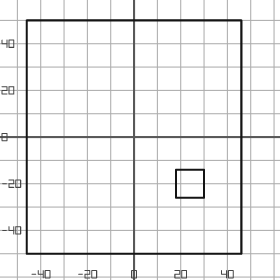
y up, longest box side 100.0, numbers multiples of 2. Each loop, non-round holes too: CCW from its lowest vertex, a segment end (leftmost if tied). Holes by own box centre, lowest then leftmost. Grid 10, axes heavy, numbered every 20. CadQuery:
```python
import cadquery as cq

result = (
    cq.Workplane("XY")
    .moveTo(-46.0, -50.0)
    .lineTo(46.0, -50.0)
    .lineTo(46.0, 50.0)
    .lineTo(-46.0, 50.0)
    .close()
    .moveTo(18.0, -26.0)
    .lineTo(30.0, -26.0)
    .lineTo(30.0, -14.0)
    .lineTo(18.0, -14.0)
    .close()
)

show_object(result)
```